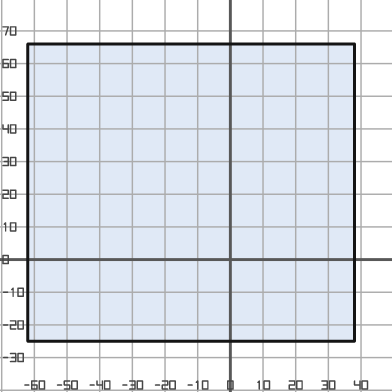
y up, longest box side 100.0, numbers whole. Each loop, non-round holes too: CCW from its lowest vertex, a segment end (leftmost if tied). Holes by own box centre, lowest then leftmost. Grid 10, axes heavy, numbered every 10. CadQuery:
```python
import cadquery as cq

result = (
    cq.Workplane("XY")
    .moveTo(-62.0, -25.0)
    .lineTo(38.0, -25.0)
    .lineTo(38.0, 66.0)
    .lineTo(-62.0, 66.0)
    .close()
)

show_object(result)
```